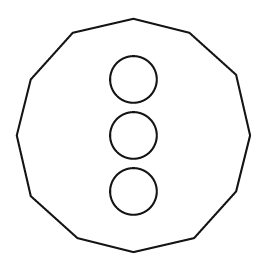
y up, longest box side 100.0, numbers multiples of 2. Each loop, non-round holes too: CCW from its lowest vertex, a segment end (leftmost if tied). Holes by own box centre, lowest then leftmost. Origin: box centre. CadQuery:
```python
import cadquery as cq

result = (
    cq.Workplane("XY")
    .moveTo(0.0, -50.0)
    .lineTo(26.0, -44.0)
    .lineTo(44.0, -24.0)
    .lineTo(50.0, 0.0)
    .lineTo(44.0, 26.0)
    .lineTo(24.0, 44.0)
    .lineTo(0.0, 50.0)
    .lineTo(-26.0, 44.0)
    .lineTo(-44.0, 24.0)
    .lineTo(-50.0, 0.0)
    .lineTo(-44.0, -26.0)
    .lineTo(-24.0, -44.0)
    .close()
    .moveTo(0.0, -24.0)
    .circle(10.0)
    .moveTo(0.0, 0.0)
    .circle(10.0)
    .moveTo(0.0, 24.0)
    .circle(10.0)
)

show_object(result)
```